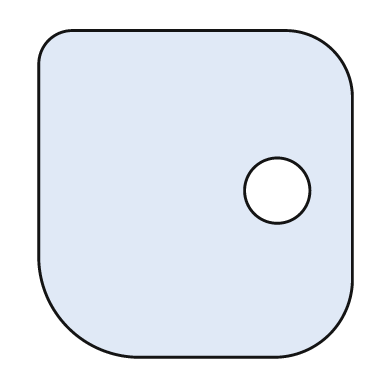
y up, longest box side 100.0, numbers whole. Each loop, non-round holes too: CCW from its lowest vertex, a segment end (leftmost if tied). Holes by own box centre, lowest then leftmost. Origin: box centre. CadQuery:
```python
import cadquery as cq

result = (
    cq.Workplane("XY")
    .moveTo(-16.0, -50.0)
    .lineTo(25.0, -50.0)
    .threePointArc((41.0, -43.0), (48.0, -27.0))
    .lineTo(48.0, 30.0)
    .threePointArc((42.0, 44.0), (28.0, 50.0))
    .lineTo(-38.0, 50.0)
    .threePointArc((-45.0, 47.0), (-48.0, 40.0))
    .lineTo(-48.0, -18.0)
    .threePointArc((-39.0, -41.0), (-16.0, -50.0))
    .close()
    .moveTo(25.0, 1.0)
    .circle(10.0)
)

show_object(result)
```